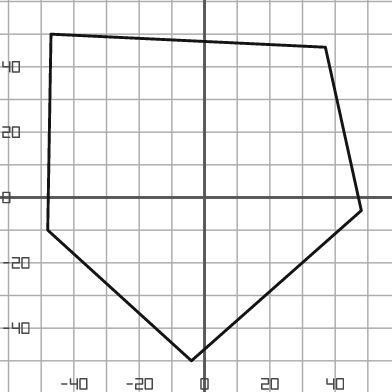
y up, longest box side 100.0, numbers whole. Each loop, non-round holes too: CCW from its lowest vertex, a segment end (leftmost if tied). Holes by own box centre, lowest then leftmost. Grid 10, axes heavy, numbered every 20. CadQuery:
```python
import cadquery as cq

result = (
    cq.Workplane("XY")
    .moveTo(-4.0, -50.0)
    .lineTo(48.0, -4.0)
    .lineTo(37.0, 46.0)
    .lineTo(-47.0, 50.0)
    .lineTo(-48.0, -10.0)
    .close()
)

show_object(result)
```